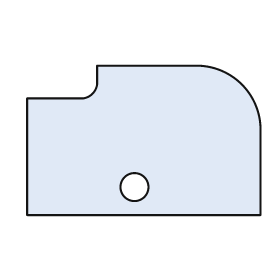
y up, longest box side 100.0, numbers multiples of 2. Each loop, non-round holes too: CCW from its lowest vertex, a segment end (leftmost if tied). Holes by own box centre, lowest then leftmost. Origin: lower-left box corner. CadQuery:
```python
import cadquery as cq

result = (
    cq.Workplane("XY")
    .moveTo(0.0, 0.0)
    .lineTo(100.0, 0.0)
    .lineTo(100.0, 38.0)
    .threePointArc((92.0, 56.0), (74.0, 64.0))
    .lineTo(30.0, 64.0)
    .lineTo(30.0, 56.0)
    .threePointArc((28.0, 52.0), (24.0, 50.0))
    .lineTo(0.0, 50.0)
    .close()
    .moveTo(46.0, 12.0)
    .circle(6.0)
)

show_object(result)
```